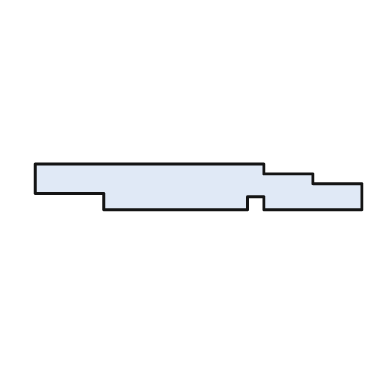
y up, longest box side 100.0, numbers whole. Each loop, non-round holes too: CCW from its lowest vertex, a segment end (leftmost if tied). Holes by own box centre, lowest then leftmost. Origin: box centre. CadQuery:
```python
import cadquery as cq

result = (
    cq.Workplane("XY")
    .moveTo(-29.0, -7.0)
    .lineTo(15.0, -7.0)
    .lineTo(15.0, -3.0)
    .lineTo(20.0, -3.0)
    .lineTo(20.0, -7.0)
    .lineTo(50.0, -7.0)
    .lineTo(50.0, 1.0)
    .lineTo(35.0, 1.0)
    .lineTo(35.0, 4.0)
    .lineTo(20.0, 4.0)
    .lineTo(20.0, 7.0)
    .lineTo(-50.0, 7.0)
    .lineTo(-50.0, -2.0)
    .lineTo(-29.0, -2.0)
    .close()
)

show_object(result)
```